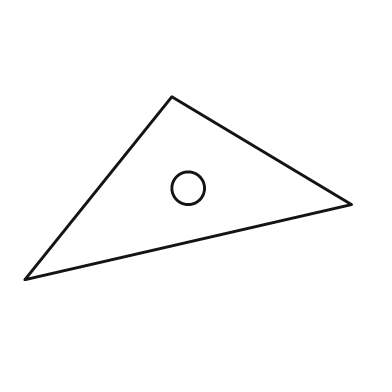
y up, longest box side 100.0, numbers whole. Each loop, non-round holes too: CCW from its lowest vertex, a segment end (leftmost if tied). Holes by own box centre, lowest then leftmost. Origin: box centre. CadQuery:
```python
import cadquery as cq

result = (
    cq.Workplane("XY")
    .moveTo(-50.0, -28.0)
    .lineTo(50.0, -5.0)
    .lineTo(-5.0, 28.0)
    .close()
    .moveTo(0.0, 0.0)
    .circle(5.0)
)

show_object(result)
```